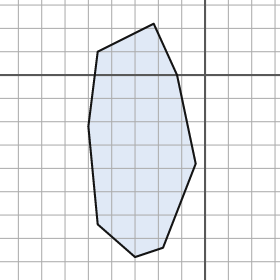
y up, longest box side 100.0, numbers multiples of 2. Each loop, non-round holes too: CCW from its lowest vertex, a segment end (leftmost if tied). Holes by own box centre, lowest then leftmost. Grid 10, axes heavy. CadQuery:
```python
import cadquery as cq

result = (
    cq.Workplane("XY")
    .moveTo(-30.0, -78.0)
    .lineTo(-18.0, -74.0)
    .lineTo(-4.0, -38.0)
    .lineTo(-12.0, 0.0)
    .lineTo(-22.0, 22.0)
    .lineTo(-46.0, 10.0)
    .lineTo(-50.0, -22.0)
    .lineTo(-46.0, -64.0)
    .close()
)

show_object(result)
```